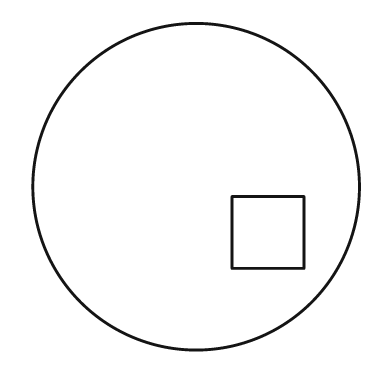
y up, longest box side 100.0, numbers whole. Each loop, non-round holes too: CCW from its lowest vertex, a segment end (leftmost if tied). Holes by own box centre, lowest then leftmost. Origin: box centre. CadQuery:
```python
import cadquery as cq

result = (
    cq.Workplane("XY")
    .moveTo(0.0, 0.0)
    .circle(50.0)
    .moveTo(11.0, -25.0)
    .lineTo(33.0, -25.0)
    .lineTo(33.0, -3.0)
    .lineTo(11.0, -3.0)
    .close()
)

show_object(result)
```